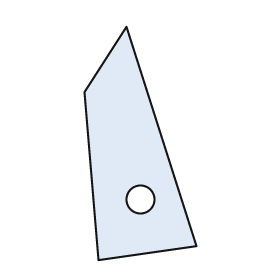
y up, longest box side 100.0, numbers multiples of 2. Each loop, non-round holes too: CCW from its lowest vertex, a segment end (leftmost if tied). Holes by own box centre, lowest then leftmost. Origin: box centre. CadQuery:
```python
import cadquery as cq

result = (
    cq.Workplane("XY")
    .moveTo(-18.0, -50.0)
    .lineTo(24.0, -44.0)
    .lineTo(-6.0, 50.0)
    .lineTo(-24.0, 22.0)
    .close()
    .moveTo(0.0, -24.0)
    .circle(6.0)
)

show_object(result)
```